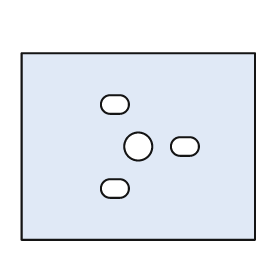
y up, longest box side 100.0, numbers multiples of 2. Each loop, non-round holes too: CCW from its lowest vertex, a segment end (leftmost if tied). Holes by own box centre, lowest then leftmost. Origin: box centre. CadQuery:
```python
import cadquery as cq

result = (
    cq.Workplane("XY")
    .moveTo(-50.0, -40.0)
    .lineTo(50.0, -40.0)
    .lineTo(50.0, 40.0)
    .lineTo(-50.0, 40.0)
    .close()
    .moveTo(-12.0, -22.0)
    .lineTo(-8.0, -22.0)
    .threePointArc((-4.0, -18.0), (-8.0, -14.0))
    .lineTo(-12.0, -14.0)
    .threePointArc((-16.0, -18.0), (-12.0, -22.0))
    .close()
    .moveTo(0.0, 0.0)
    .circle(6.0)
    .moveTo(18.0, -4.0)
    .lineTo(22.0, -4.0)
    .threePointArc((26.0, 0.0), (22.0, 4.0))
    .lineTo(18.0, 4.0)
    .threePointArc((14.0, 0.0), (18.0, -4.0))
    .close()
    .moveTo(-12.0, 14.0)
    .lineTo(-8.0, 14.0)
    .threePointArc((-4.0, 18.0), (-8.0, 22.0))
    .lineTo(-12.0, 22.0)
    .threePointArc((-16.0, 18.0), (-12.0, 14.0))
    .close()
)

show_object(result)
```